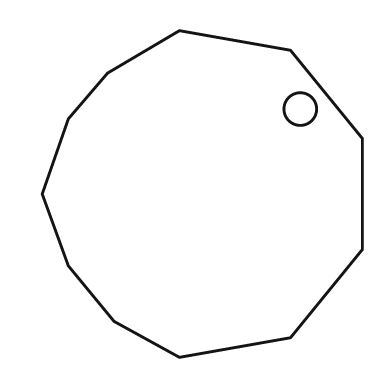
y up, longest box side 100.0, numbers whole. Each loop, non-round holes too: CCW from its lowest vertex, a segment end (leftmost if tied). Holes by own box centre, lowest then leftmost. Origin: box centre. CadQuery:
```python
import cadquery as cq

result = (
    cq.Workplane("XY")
    .moveTo(-7.0, -50.0)
    .lineTo(27.0, -44.0)
    .lineTo(49.0, -17.0)
    .lineTo(49.0, 17.0)
    .lineTo(27.0, 44.0)
    .lineTo(-7.0, 50.0)
    .lineTo(-29.0, 37.0)
    .lineTo(-41.0, 23.0)
    .lineTo(-49.0, 0.0)
    .lineTo(-41.0, -22.0)
    .lineTo(-27.0, -39.0)
    .close()
    .moveTo(30.0, 26.0)
    .circle(5.0)
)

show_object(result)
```